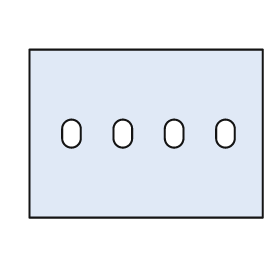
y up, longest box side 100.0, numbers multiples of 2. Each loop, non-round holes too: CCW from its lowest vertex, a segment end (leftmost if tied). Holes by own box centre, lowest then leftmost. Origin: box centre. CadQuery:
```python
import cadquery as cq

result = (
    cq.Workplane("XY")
    .moveTo(-50.0, -36.0)
    .lineTo(50.0, -36.0)
    .lineTo(50.0, 36.0)
    .lineTo(-50.0, 36.0)
    .close()
    .moveTo(-36.0, -2.0)
    .threePointArc((-32.0, -6.0), (-28.0, -2.0))
    .lineTo(-28.0, 2.0)
    .threePointArc((-32.0, 6.0), (-36.0, 2.0))
    .close()
    .moveTo(-14.0, -2.0)
    .threePointArc((-10.0, -6.0), (-6.0, -2.0))
    .lineTo(-6.0, 2.0)
    .threePointArc((-10.0, 6.0), (-14.0, 2.0))
    .close()
    .moveTo(8.0, -2.0)
    .threePointArc((12.0, -6.0), (16.0, -2.0))
    .lineTo(16.0, 2.0)
    .threePointArc((12.0, 6.0), (8.0, 2.0))
    .close()
    .moveTo(30.0, -2.0)
    .threePointArc((34.0, -6.0), (38.0, -2.0))
    .lineTo(38.0, 2.0)
    .threePointArc((34.0, 6.0), (30.0, 2.0))
    .close()
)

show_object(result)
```